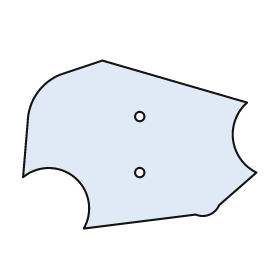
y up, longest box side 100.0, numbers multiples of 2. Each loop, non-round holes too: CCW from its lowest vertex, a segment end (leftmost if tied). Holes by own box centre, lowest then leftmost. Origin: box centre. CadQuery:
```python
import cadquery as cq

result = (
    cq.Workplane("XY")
    .moveTo(-24.0, -36.0)
    .lineTo(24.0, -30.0)
    .threePointArc((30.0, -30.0), (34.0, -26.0))
    .lineTo(50.0, -12.0)
    .threePointArc((40.0, 2.0), (46.0, 18.0))
    .lineTo(-16.0, 36.0)
    .lineTo(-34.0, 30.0)
    .threePointArc((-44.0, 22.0), (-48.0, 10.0))
    .lineTo(-50.0, -14.0)
    .threePointArc((-28.0, -14.0), (-24.0, -36.0))
    .close()
    .moveTo(0.0, -12.0)
    .circle(2.0)
    .moveTo(0.0, 12.0)
    .circle(2.0)
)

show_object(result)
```